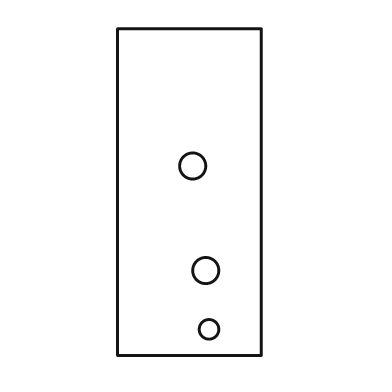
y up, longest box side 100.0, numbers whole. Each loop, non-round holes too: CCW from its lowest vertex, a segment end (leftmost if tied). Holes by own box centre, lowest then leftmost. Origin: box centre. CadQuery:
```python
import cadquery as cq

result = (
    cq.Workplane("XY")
    .moveTo(-22.0, -50.0)
    .lineTo(22.0, -50.0)
    .lineTo(22.0, 50.0)
    .lineTo(-22.0, 50.0)
    .close()
    .moveTo(6.0, -42.0)
    .circle(3.0)
    .moveTo(5.0, -24.0)
    .circle(4.0)
    .moveTo(1.0, 8.0)
    .circle(4.0)
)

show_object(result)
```